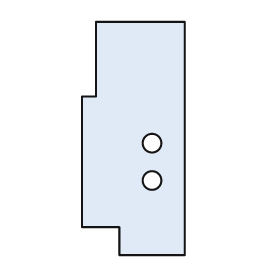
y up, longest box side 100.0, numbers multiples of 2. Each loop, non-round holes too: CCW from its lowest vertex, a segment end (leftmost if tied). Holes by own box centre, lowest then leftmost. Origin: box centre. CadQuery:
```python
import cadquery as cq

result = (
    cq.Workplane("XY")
    .moveTo(-6.0, -50.0)
    .lineTo(22.0, -50.0)
    .lineTo(22.0, 50.0)
    .lineTo(-16.0, 50.0)
    .lineTo(-16.0, 18.0)
    .lineTo(-22.0, 18.0)
    .lineTo(-22.0, -38.0)
    .lineTo(-6.0, -38.0)
    .close()
    .moveTo(8.0, -18.0)
    .circle(4.0)
    .moveTo(8.0, -2.0)
    .circle(4.0)
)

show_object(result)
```